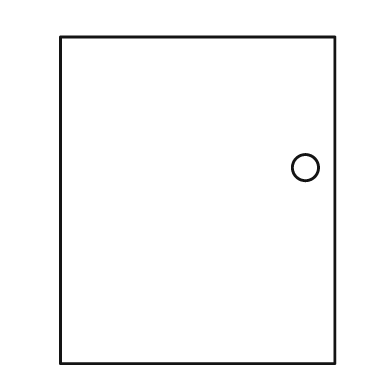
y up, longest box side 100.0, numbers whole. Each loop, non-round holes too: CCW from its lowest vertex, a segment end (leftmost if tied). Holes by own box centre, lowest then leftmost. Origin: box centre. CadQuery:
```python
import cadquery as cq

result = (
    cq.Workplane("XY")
    .moveTo(-42.0, -50.0)
    .lineTo(42.0, -50.0)
    .lineTo(42.0, 50.0)
    .lineTo(-42.0, 50.0)
    .close()
    .moveTo(33.0, 10.0)
    .circle(4.0)
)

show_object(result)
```